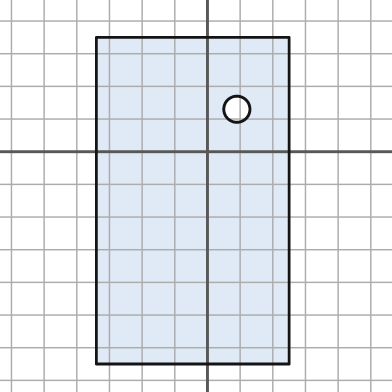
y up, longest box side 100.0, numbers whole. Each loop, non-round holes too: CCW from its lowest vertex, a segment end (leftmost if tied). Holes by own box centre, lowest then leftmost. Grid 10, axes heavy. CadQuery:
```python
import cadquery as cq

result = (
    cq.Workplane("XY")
    .moveTo(-34.0, -65.0)
    .lineTo(25.0, -65.0)
    .lineTo(25.0, 35.0)
    .lineTo(-34.0, 35.0)
    .close()
    .moveTo(9.0, 13.0)
    .circle(4.0)
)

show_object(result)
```